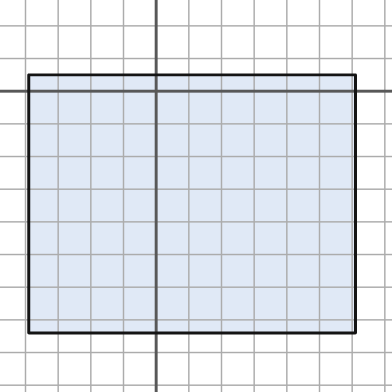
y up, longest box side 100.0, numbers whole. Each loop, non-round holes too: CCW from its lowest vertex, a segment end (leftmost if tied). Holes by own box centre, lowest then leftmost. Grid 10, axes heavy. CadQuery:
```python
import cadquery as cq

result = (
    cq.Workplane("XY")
    .moveTo(-39.0, -74.0)
    .lineTo(61.0, -74.0)
    .lineTo(61.0, 5.0)
    .lineTo(-39.0, 5.0)
    .close()
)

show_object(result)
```